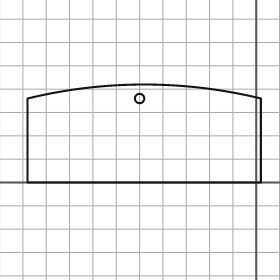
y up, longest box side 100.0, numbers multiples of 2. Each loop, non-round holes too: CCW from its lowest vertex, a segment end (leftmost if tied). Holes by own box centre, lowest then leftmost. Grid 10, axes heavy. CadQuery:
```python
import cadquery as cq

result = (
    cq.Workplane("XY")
    .moveTo(-98.0, 0.0)
    .lineTo(2.0, 0.0)
    .lineTo(2.0, 36.0)
    .threePointArc((-48.0, 42.0), (-98.0, 36.0))
    .close()
    .moveTo(-50.0, 36.0)
    .circle(2.0)
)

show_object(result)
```